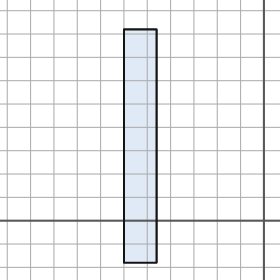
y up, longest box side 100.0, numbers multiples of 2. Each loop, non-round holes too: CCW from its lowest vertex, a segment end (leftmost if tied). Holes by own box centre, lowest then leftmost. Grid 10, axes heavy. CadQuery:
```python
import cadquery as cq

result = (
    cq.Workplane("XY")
    .moveTo(-60.0, -18.0)
    .lineTo(-46.0, -18.0)
    .lineTo(-46.0, 82.0)
    .lineTo(-60.0, 82.0)
    .close()
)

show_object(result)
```